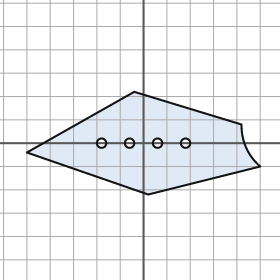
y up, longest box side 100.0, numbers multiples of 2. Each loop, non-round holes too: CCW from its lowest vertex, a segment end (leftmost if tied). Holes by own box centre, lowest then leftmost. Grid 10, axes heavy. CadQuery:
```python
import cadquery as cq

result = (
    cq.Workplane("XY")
    .moveTo(2.0, -22.0)
    .lineTo(50.0, -10.0)
    .threePointArc((44.0, -2.0), (42.0, 8.0))
    .lineTo(-4.0, 22.0)
    .lineTo(-50.0, -4.0)
    .close()
    .moveTo(-18.0, 0.0)
    .circle(2.0)
    .moveTo(-6.0, 0.0)
    .circle(2.0)
    .moveTo(6.0, 0.0)
    .circle(2.0)
    .moveTo(18.0, 0.0)
    .circle(2.0)
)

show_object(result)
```